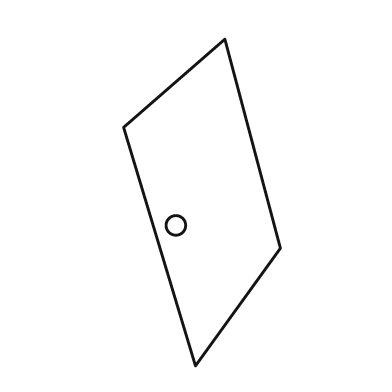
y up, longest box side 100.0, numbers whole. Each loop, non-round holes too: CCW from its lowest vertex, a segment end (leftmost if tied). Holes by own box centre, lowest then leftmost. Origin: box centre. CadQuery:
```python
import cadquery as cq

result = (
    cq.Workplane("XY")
    .moveTo(-2.0, -50.0)
    .lineTo(24.0, -14.0)
    .lineTo(7.0, 50.0)
    .lineTo(-24.0, 23.0)
    .close()
    .moveTo(-8.0, -7.0)
    .circle(3.0)
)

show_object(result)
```